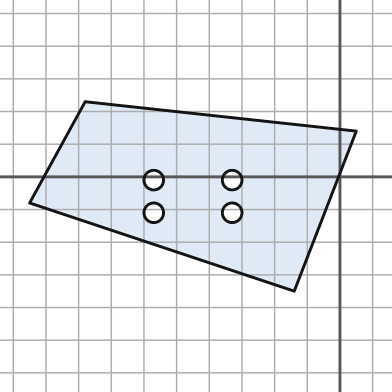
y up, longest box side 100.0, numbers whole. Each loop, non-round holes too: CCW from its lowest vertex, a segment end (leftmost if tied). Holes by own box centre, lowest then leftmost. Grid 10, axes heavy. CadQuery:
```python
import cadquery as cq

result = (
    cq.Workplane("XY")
    .moveTo(-14.0, -35.0)
    .lineTo(5.0, 14.0)
    .lineTo(-78.0, 23.0)
    .lineTo(-95.0, -8.0)
    .close()
    .moveTo(-57.0, -11.0)
    .circle(3.0)
    .moveTo(-33.0, -11.0)
    .circle(3.0)
    .moveTo(-57.0, -1.0)
    .circle(3.0)
    .moveTo(-33.0, -1.0)
    .circle(3.0)
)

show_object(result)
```